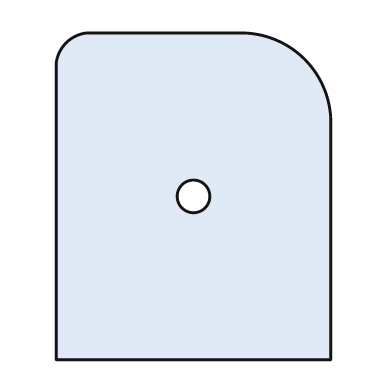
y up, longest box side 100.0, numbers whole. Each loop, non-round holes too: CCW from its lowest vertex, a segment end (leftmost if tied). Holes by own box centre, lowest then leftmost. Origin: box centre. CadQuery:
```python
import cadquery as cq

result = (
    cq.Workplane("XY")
    .moveTo(-42.0, -50.0)
    .lineTo(42.0, -50.0)
    .lineTo(42.0, 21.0)
    .threePointArc((34.0, 42.0), (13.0, 50.0))
    .lineTo(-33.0, 50.0)
    .threePointArc((-39.0, 47.0), (-42.0, 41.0))
    .close()
    .moveTo(0.0, 0.0)
    .circle(5.0)
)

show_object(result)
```